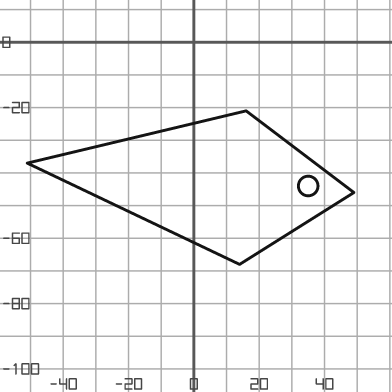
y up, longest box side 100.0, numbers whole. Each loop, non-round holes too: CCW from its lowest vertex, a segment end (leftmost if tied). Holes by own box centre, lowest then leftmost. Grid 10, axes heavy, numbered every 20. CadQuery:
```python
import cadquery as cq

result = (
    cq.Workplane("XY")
    .moveTo(14.0, -68.0)
    .lineTo(49.0, -46.0)
    .lineTo(16.0, -21.0)
    .lineTo(-51.0, -37.0)
    .close()
    .moveTo(35.0, -44.0)
    .circle(3.0)
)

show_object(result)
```